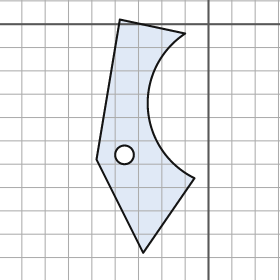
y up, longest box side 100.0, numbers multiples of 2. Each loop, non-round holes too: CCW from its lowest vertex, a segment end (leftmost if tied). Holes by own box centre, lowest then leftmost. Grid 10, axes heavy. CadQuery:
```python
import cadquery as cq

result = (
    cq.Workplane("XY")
    .moveTo(-28.0, -98.0)
    .lineTo(-6.0, -66.0)
    .threePointArc((-26.0, -36.0), (-10.0, -4.0))
    .lineTo(-38.0, 2.0)
    .lineTo(-48.0, -58.0)
    .close()
    .moveTo(-36.0, -56.0)
    .circle(4.0)
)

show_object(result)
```